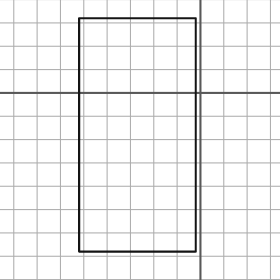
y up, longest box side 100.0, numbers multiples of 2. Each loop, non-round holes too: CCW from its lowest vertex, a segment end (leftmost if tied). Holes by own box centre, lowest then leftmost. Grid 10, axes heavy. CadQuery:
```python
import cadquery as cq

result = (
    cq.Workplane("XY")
    .moveTo(-52.0, -68.0)
    .lineTo(-2.0, -68.0)
    .lineTo(-2.0, 32.0)
    .lineTo(-52.0, 32.0)
    .close()
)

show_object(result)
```